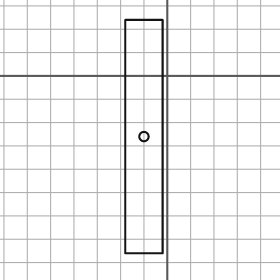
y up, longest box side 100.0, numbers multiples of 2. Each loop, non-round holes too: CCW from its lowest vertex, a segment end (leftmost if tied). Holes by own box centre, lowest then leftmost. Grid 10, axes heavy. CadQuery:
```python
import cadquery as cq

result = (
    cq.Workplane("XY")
    .moveTo(-18.0, -76.0)
    .lineTo(-2.0, -76.0)
    .lineTo(-2.0, 24.0)
    .lineTo(-18.0, 24.0)
    .close()
    .moveTo(-10.0, -26.0)
    .circle(2.0)
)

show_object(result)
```